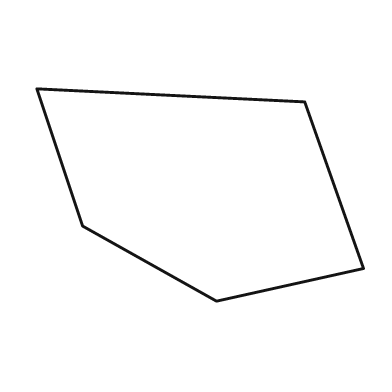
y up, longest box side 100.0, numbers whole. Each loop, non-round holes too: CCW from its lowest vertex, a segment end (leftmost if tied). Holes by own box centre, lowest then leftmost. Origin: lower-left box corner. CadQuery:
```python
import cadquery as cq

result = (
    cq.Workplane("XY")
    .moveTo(55.0, 0.0)
    .lineTo(100.0, 10.0)
    .lineTo(82.0, 61.0)
    .lineTo(0.0, 65.0)
    .lineTo(14.0, 23.0)
    .close()
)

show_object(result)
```